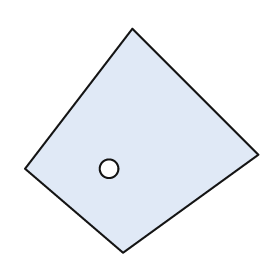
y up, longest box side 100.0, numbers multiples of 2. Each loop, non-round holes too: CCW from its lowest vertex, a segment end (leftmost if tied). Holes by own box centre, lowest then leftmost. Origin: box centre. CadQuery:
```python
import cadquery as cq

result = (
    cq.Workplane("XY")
    .moveTo(-8.0, -48.0)
    .lineTo(50.0, -6.0)
    .lineTo(-4.0, 48.0)
    .lineTo(-50.0, -12.0)
    .close()
    .moveTo(-14.0, -12.0)
    .circle(4.0)
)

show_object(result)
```